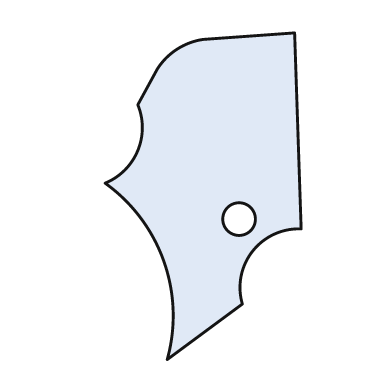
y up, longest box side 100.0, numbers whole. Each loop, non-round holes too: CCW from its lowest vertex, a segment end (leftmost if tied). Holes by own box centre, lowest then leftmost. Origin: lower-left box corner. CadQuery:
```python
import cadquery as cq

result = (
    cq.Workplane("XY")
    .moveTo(19.0, 0.0)
    .lineTo(42.0, 17.0)
    .threePointArc((45.0, 33.0), (60.0, 40.0))
    .lineTo(58.0, 100.0)
    .lineTo(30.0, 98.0)
    .threePointArc((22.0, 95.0), (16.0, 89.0))
    .lineTo(10.0, 78.0)
    .threePointArc((10.0, 64.0), (0.0, 54.0))
    .threePointArc((18.0, 30.0), (19.0, 0.0))
    .close()
    .moveTo(41.0, 43.0)
    .circle(5.0)
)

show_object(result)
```